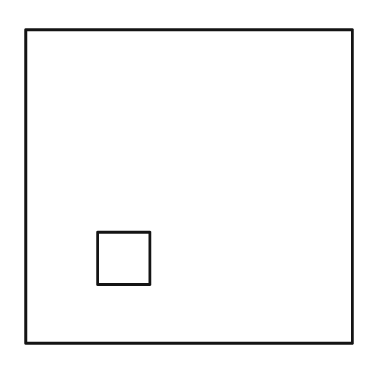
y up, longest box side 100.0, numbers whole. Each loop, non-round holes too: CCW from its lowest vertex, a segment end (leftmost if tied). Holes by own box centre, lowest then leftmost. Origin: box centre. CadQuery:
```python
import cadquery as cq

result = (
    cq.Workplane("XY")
    .moveTo(-50.0, -48.0)
    .lineTo(50.0, -48.0)
    .lineTo(50.0, 48.0)
    .lineTo(-50.0, 48.0)
    .close()
    .moveTo(-28.0, -30.0)
    .lineTo(-12.0, -30.0)
    .lineTo(-12.0, -14.0)
    .lineTo(-28.0, -14.0)
    .close()
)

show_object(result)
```